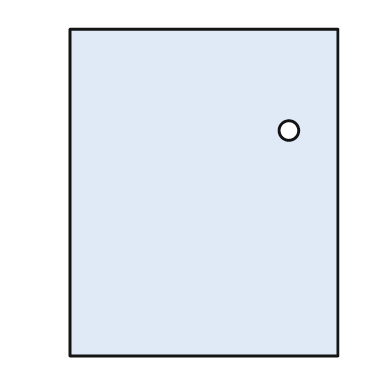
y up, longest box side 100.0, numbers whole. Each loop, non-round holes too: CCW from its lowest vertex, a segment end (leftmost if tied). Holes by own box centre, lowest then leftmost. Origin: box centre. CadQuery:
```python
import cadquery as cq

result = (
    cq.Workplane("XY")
    .moveTo(-41.0, -50.0)
    .lineTo(41.0, -50.0)
    .lineTo(41.0, 50.0)
    .lineTo(-41.0, 50.0)
    .close()
    .moveTo(26.0, 19.0)
    .circle(3.0)
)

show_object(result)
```